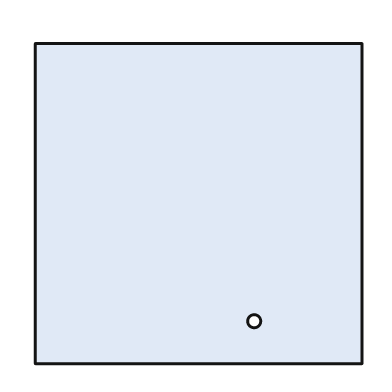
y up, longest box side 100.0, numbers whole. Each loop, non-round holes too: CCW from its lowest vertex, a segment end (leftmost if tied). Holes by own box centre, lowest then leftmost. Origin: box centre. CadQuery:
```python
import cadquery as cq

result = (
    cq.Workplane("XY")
    .moveTo(-50.0, -49.0)
    .lineTo(50.0, -49.0)
    .lineTo(50.0, 49.0)
    .lineTo(-50.0, 49.0)
    .close()
    .moveTo(17.0, -36.0)
    .circle(2.0)
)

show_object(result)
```